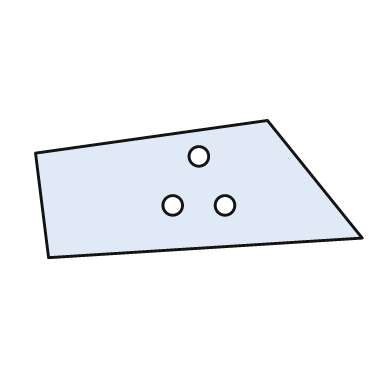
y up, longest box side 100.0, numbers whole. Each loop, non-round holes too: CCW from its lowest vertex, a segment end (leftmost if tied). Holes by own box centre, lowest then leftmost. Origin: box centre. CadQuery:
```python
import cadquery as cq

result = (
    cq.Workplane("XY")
    .moveTo(-46.0, -21.0)
    .lineTo(50.0, -15.0)
    .lineTo(21.0, 21.0)
    .lineTo(-50.0, 11.0)
    .close()
    .moveTo(-8.0, -5.0)
    .circle(3.0)
    .moveTo(8.0, -5.0)
    .circle(3.0)
    .moveTo(0.0, 10.0)
    .circle(3.0)
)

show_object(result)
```